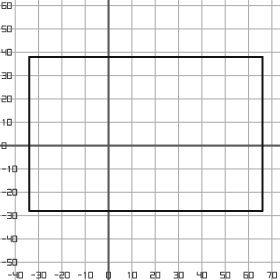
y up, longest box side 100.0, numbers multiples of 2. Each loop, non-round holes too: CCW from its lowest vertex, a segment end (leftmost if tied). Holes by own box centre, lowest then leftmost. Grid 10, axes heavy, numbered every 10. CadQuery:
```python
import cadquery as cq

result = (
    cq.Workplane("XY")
    .moveTo(-34.0, -28.0)
    .lineTo(66.0, -28.0)
    .lineTo(66.0, 38.0)
    .lineTo(-34.0, 38.0)
    .close()
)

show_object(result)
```